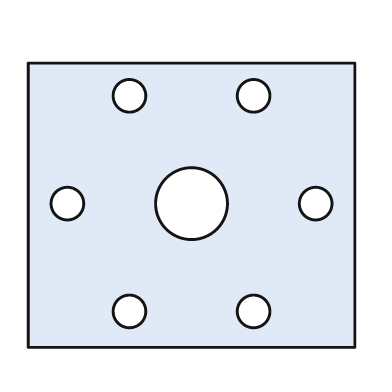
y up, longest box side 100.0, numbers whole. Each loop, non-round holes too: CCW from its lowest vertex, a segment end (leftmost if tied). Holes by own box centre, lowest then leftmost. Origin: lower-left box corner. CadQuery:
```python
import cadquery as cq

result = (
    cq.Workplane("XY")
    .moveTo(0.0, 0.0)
    .lineTo(100.0, 0.0)
    .lineTo(100.0, 87.0)
    .lineTo(0.0, 87.0)
    .close()
    .moveTo(31.0, 11.0)
    .circle(5.0)
    .moveTo(69.0, 11.0)
    .circle(5.0)
    .moveTo(12.0, 44.0)
    .circle(5.0)
    .moveTo(50.0, 44.0)
    .circle(11.0)
    .moveTo(88.0, 44.0)
    .circle(5.0)
    .moveTo(31.0, 77.0)
    .circle(5.0)
    .moveTo(69.0, 77.0)
    .circle(5.0)
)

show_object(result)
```